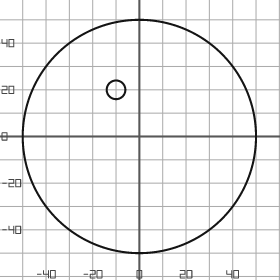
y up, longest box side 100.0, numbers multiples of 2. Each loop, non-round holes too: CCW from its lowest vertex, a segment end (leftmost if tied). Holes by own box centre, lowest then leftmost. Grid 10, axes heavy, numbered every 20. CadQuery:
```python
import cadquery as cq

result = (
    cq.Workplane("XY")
    .moveTo(0.0, 0.0)
    .circle(50.0)
    .moveTo(-10.0, 20.0)
    .circle(4.0)
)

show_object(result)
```